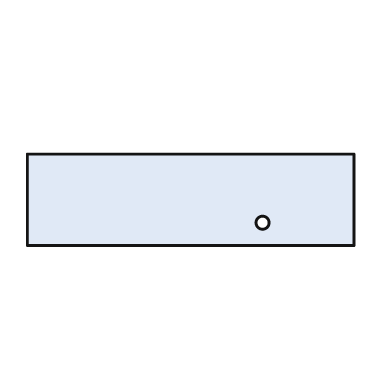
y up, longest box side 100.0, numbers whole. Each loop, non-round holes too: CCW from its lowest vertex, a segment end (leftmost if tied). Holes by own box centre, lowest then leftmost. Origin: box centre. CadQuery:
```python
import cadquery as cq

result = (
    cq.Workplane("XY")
    .moveTo(-50.0, -14.0)
    .lineTo(50.0, -14.0)
    .lineTo(50.0, 14.0)
    .lineTo(-50.0, 14.0)
    .close()
    .moveTo(22.0, -7.0)
    .circle(2.0)
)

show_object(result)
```